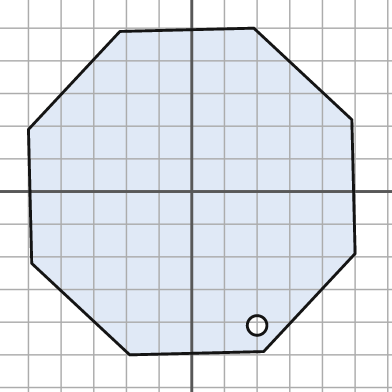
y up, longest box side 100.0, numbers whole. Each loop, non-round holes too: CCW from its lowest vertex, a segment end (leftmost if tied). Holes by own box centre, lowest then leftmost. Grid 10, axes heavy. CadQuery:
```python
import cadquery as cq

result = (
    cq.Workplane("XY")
    .moveTo(-19.0, -50.0)
    .lineTo(22.0, -49.0)
    .lineTo(50.0, -19.0)
    .lineTo(49.0, 22.0)
    .lineTo(19.0, 50.0)
    .lineTo(-22.0, 49.0)
    .lineTo(-50.0, 19.0)
    .lineTo(-49.0, -22.0)
    .close()
    .moveTo(20.0, -41.0)
    .circle(3.0)
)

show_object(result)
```